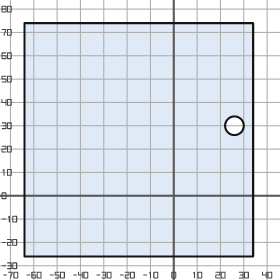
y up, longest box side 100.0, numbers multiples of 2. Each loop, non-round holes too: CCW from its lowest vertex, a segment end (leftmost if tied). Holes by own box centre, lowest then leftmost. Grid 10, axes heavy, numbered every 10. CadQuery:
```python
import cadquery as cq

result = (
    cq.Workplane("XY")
    .moveTo(-64.0, -26.0)
    .lineTo(34.0, -26.0)
    .lineTo(34.0, 74.0)
    .lineTo(-64.0, 74.0)
    .close()
    .moveTo(26.0, 30.0)
    .circle(4.0)
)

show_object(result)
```